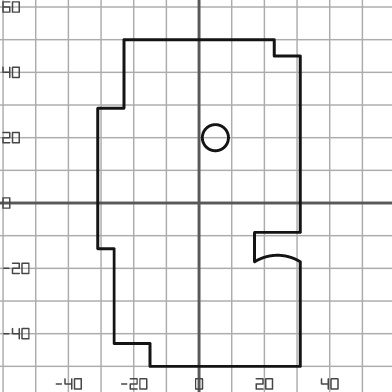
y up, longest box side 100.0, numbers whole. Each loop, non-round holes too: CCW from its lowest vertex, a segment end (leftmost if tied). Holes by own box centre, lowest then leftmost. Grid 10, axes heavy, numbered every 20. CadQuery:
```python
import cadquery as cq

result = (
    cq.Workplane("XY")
    .moveTo(-15.0, -50.0)
    .lineTo(31.0, -50.0)
    .lineTo(31.0, -18.0)
    .threePointArc((24.0, -16.0), (17.0, -18.0))
    .lineTo(17.0, -9.0)
    .lineTo(31.0, -9.0)
    .lineTo(31.0, 45.0)
    .lineTo(23.0, 45.0)
    .lineTo(23.0, 50.0)
    .lineTo(-23.0, 50.0)
    .lineTo(-23.0, 29.0)
    .lineTo(-31.0, 29.0)
    .lineTo(-31.0, -14.0)
    .lineTo(-26.0, -14.0)
    .lineTo(-26.0, -43.0)
    .lineTo(-15.0, -43.0)
    .close()
    .moveTo(5.0, 20.0)
    .circle(4.0)
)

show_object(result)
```